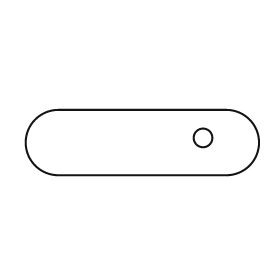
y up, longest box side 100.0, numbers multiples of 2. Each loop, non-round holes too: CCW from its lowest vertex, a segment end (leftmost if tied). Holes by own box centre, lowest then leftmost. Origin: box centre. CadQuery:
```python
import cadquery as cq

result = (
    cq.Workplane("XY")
    .moveTo(-36.0, -14.0)
    .lineTo(36.0, -14.0)
    .threePointArc((50.0, 0.0), (36.0, 14.0))
    .lineTo(-36.0, 14.0)
    .threePointArc((-50.0, 0.0), (-36.0, -14.0))
    .close()
    .moveTo(26.0, 2.0)
    .circle(4.0)
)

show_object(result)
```